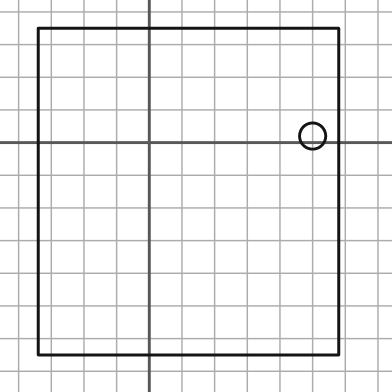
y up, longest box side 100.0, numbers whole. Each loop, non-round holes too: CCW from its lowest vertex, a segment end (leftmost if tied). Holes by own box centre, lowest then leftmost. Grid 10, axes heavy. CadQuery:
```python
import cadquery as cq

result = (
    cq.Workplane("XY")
    .moveTo(-34.0, -65.0)
    .lineTo(58.0, -65.0)
    .lineTo(58.0, 35.0)
    .lineTo(-34.0, 35.0)
    .close()
    .moveTo(50.0, 2.0)
    .circle(4.0)
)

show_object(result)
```